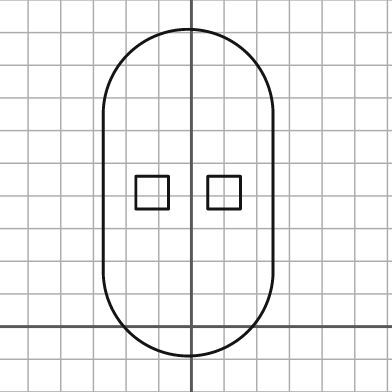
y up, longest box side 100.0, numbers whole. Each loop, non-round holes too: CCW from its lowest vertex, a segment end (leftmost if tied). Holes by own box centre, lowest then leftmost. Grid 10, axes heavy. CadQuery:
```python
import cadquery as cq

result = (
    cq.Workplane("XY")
    .moveTo(-27.0, 17.0)
    .threePointArc((-1.0, -9.0), (25.0, 17.0))
    .lineTo(25.0, 65.0)
    .threePointArc((-1.0, 91.0), (-27.0, 65.0))
    .close()
    .moveTo(-17.0, 36.0)
    .lineTo(-7.0, 36.0)
    .lineTo(-7.0, 46.0)
    .lineTo(-17.0, 46.0)
    .close()
    .moveTo(5.0, 36.0)
    .lineTo(15.0, 36.0)
    .lineTo(15.0, 46.0)
    .lineTo(5.0, 46.0)
    .close()
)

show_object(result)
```